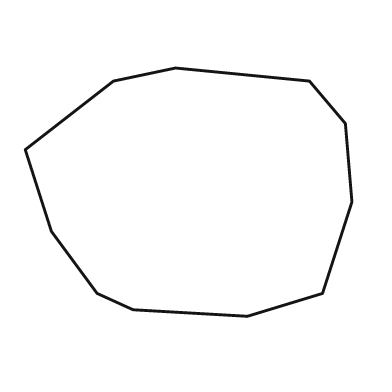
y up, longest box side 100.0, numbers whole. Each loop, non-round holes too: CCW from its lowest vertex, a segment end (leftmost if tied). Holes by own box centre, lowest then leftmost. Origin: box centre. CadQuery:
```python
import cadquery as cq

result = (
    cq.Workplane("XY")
    .moveTo(18.0, -38.0)
    .lineTo(41.0, -31.0)
    .lineTo(50.0, -3.0)
    .lineTo(48.0, 21.0)
    .lineTo(37.0, 34.0)
    .lineTo(-4.0, 38.0)
    .lineTo(-23.0, 34.0)
    .lineTo(-50.0, 13.0)
    .lineTo(-42.0, -12.0)
    .lineTo(-28.0, -31.0)
    .lineTo(-17.0, -36.0)
    .close()
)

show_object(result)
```